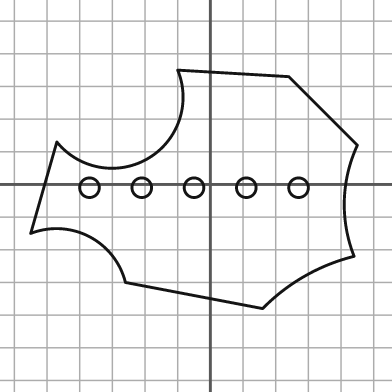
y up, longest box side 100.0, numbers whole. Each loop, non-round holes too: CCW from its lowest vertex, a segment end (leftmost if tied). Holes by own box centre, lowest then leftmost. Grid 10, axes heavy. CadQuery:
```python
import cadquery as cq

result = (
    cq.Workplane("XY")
    .moveTo(16.0, -38.0)
    .threePointArc((29.0, -28.0), (44.0, -22.0))
    .threePointArc((41.0, -5.0), (45.0, 12.0))
    .lineTo(24.0, 33.0)
    .lineTo(-10.0, 35.0)
    .threePointArc((-19.0, 8.0), (-47.0, 13.0))
    .lineTo(-55.0, -15.0)
    .threePointArc((-37.0, -16.0), (-26.0, -30.0))
    .close()
    .moveTo(-37.0, -1.0)
    .circle(3.0)
    .moveTo(-21.0, -1.0)
    .circle(3.0)
    .moveTo(-5.0, -1.0)
    .circle(3.0)
    .moveTo(11.0, -1.0)
    .circle(3.0)
    .moveTo(27.0, -1.0)
    .circle(3.0)
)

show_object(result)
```